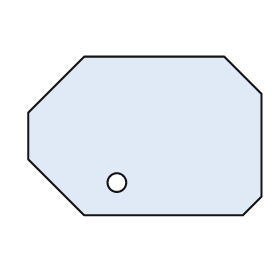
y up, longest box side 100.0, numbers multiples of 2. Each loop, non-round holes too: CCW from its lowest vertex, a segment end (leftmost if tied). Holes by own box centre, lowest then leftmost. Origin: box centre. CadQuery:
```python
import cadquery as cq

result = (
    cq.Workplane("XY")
    .moveTo(-26.0, -34.0)
    .lineTo(42.0, -34.0)
    .lineTo(50.0, -26.0)
    .lineTo(50.0, 18.0)
    .lineTo(34.0, 34.0)
    .lineTo(-26.0, 34.0)
    .lineTo(-50.0, 10.0)
    .lineTo(-50.0, -10.0)
    .close()
    .moveTo(-12.0, -20.0)
    .circle(4.0)
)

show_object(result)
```